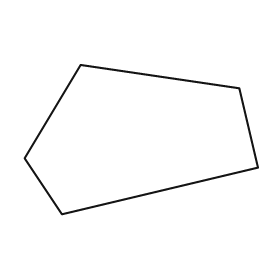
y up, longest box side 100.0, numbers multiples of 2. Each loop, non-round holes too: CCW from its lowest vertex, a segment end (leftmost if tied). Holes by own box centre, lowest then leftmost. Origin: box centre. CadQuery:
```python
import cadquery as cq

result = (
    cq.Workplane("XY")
    .moveTo(-34.0, -32.0)
    .lineTo(50.0, -12.0)
    .lineTo(42.0, 22.0)
    .lineTo(-26.0, 32.0)
    .lineTo(-50.0, -8.0)
    .close()
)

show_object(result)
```